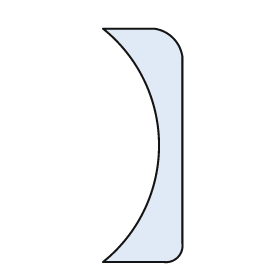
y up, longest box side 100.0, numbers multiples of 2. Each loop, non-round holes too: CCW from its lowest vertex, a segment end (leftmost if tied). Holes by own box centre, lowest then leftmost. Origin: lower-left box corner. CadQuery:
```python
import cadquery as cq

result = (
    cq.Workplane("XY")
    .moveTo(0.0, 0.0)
    .lineTo(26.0, 0.0)
    .threePointArc((32.0, 2.0), (34.0, 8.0))
    .lineTo(34.0, 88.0)
    .threePointArc((30.0, 96.0), (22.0, 100.0))
    .lineTo(0.0, 100.0)
    .threePointArc((24.0, 50.0), (0.0, 0.0))
    .close()
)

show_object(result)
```